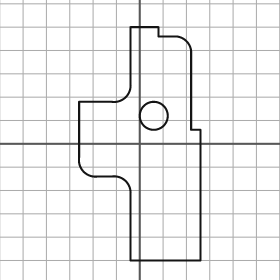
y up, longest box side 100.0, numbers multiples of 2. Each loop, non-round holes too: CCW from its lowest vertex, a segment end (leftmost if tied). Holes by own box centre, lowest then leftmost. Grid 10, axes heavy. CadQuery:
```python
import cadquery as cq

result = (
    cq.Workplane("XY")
    .moveTo(-4.0, -50.0)
    .lineTo(26.0, -50.0)
    .lineTo(26.0, 6.0)
    .lineTo(22.0, 6.0)
    .lineTo(22.0, 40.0)
    .threePointArc((20.0, 44.0), (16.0, 46.0))
    .lineTo(8.0, 46.0)
    .lineTo(8.0, 50.0)
    .lineTo(-4.0, 50.0)
    .lineTo(-4.0, 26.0)
    .threePointArc((-6.0, 20.0), (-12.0, 18.0))
    .lineTo(-26.0, 18.0)
    .lineTo(-26.0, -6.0)
    .threePointArc((-24.0, -12.0), (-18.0, -14.0))
    .lineTo(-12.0, -14.0)
    .threePointArc((-6.0, -16.0), (-4.0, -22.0))
    .close()
    .moveTo(6.0, 12.0)
    .circle(6.0)
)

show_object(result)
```